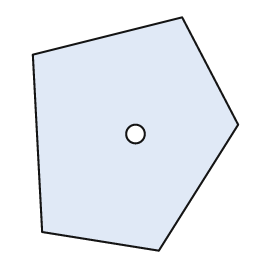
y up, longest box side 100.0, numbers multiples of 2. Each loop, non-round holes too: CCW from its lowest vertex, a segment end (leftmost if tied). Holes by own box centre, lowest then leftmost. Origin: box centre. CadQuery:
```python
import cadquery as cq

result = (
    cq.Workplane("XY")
    .moveTo(10.0, -50.0)
    .lineTo(44.0, 4.0)
    .lineTo(20.0, 50.0)
    .lineTo(-44.0, 34.0)
    .lineTo(-40.0, -42.0)
    .close()
    .moveTo(0.0, 0.0)
    .circle(4.0)
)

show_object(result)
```